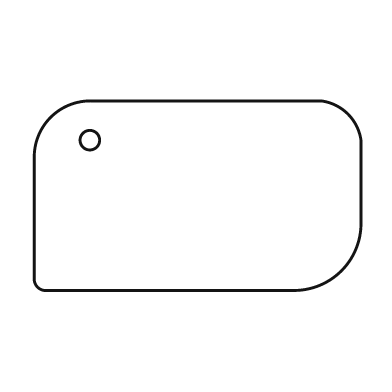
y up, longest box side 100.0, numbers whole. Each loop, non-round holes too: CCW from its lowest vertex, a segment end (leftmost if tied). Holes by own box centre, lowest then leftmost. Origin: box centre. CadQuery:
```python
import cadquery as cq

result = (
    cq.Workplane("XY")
    .moveTo(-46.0, -29.0)
    .lineTo(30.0, -29.0)
    .threePointArc((44.0, -23.0), (50.0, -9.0))
    .lineTo(50.0, 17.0)
    .threePointArc((46.0, 25.0), (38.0, 29.0))
    .lineTo(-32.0, 29.0)
    .threePointArc((-45.0, 24.0), (-50.0, 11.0))
    .lineTo(-50.0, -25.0)
    .threePointArc((-49.0, -28.0), (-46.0, -29.0))
    .close()
    .moveTo(-33.0, 17.0)
    .circle(3.0)
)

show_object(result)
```